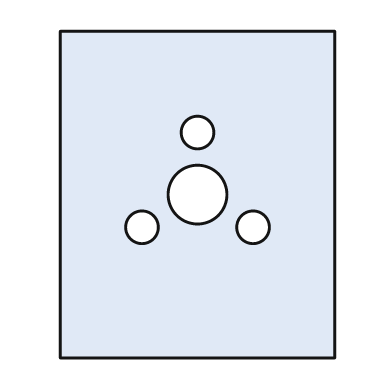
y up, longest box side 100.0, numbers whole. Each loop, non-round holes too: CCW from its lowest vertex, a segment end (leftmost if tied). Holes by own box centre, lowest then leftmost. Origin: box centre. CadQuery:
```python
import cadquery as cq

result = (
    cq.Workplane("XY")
    .moveTo(-42.0, -50.0)
    .lineTo(42.0, -50.0)
    .lineTo(42.0, 50.0)
    .lineTo(-42.0, 50.0)
    .close()
    .moveTo(-17.0, -10.0)
    .circle(5.0)
    .moveTo(17.0, -10.0)
    .circle(5.0)
    .moveTo(0.0, 0.0)
    .circle(9.0)
    .moveTo(0.0, 19.0)
    .circle(5.0)
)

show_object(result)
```